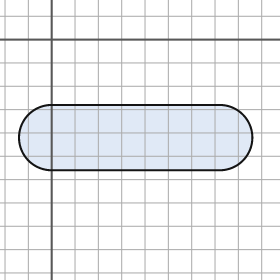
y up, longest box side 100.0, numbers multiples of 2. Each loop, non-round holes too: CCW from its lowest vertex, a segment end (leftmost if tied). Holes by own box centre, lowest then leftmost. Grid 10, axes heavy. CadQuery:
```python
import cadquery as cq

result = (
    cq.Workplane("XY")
    .moveTo(0.0, -56.0)
    .lineTo(72.0, -56.0)
    .threePointArc((86.0, -42.0), (72.0, -28.0))
    .lineTo(0.0, -28.0)
    .threePointArc((-14.0, -42.0), (0.0, -56.0))
    .close()
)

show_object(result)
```